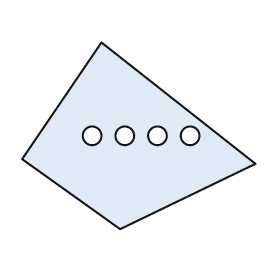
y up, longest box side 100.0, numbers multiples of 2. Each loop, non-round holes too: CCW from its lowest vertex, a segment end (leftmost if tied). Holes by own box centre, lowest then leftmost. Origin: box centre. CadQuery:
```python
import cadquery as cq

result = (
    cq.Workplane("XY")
    .moveTo(-8.0, -40.0)
    .lineTo(50.0, -12.0)
    .lineTo(-16.0, 40.0)
    .lineTo(-50.0, -10.0)
    .close()
    .moveTo(-20.0, 0.0)
    .circle(4.0)
    .moveTo(-6.0, 0.0)
    .circle(4.0)
    .moveTo(8.0, 0.0)
    .circle(4.0)
    .moveTo(22.0, 0.0)
    .circle(4.0)
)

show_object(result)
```